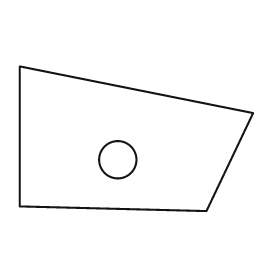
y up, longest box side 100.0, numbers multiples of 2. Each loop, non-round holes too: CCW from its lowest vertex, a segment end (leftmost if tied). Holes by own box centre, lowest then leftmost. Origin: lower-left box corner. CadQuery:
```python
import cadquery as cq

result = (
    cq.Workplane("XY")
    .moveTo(80.0, 0.0)
    .lineTo(100.0, 42.0)
    .lineTo(0.0, 62.0)
    .lineTo(0.0, 2.0)
    .close()
    .moveTo(42.0, 22.0)
    .circle(8.0)
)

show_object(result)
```